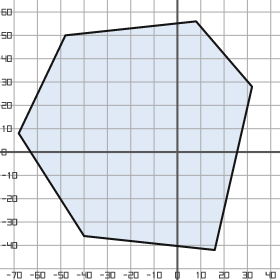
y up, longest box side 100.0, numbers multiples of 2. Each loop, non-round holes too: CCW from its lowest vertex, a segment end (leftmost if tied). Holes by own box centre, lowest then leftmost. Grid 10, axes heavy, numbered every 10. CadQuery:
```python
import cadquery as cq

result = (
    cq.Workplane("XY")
    .moveTo(16.0, -42.0)
    .lineTo(32.0, 28.0)
    .lineTo(8.0, 56.0)
    .lineTo(-48.0, 50.0)
    .lineTo(-68.0, 8.0)
    .lineTo(-40.0, -36.0)
    .close()
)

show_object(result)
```